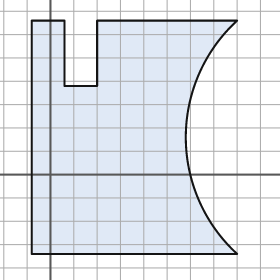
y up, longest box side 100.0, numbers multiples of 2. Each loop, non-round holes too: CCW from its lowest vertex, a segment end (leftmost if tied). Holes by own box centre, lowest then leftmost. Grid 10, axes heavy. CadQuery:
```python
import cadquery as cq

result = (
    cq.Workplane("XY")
    .moveTo(-8.0, -34.0)
    .lineTo(80.0, -34.0)
    .threePointArc((58.0, 16.0), (80.0, 66.0))
    .lineTo(20.0, 66.0)
    .lineTo(20.0, 38.0)
    .lineTo(6.0, 38.0)
    .lineTo(6.0, 66.0)
    .lineTo(-8.0, 66.0)
    .close()
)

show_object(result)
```